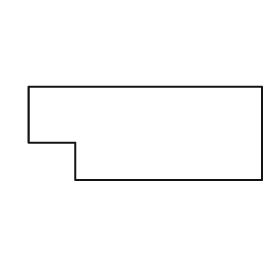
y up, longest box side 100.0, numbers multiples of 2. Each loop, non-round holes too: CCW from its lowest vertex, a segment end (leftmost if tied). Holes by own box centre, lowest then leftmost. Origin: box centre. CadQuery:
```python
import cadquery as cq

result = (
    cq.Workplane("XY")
    .moveTo(-30.0, -20.0)
    .lineTo(50.0, -20.0)
    .lineTo(50.0, 20.0)
    .lineTo(-50.0, 20.0)
    .lineTo(-50.0, -4.0)
    .lineTo(-30.0, -4.0)
    .close()
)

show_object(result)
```